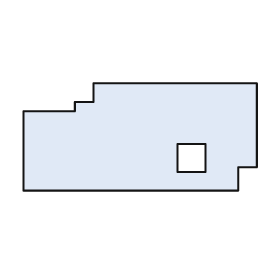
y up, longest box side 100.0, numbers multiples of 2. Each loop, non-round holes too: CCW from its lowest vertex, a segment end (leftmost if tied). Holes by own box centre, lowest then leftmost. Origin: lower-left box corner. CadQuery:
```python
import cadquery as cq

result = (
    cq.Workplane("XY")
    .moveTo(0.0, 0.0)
    .lineTo(92.0, 0.0)
    .lineTo(92.0, 10.0)
    .lineTo(100.0, 10.0)
    .lineTo(100.0, 46.0)
    .lineTo(30.0, 46.0)
    .lineTo(30.0, 38.0)
    .lineTo(22.0, 38.0)
    .lineTo(22.0, 34.0)
    .lineTo(0.0, 34.0)
    .close()
    .moveTo(66.0, 8.0)
    .lineTo(78.0, 8.0)
    .lineTo(78.0, 20.0)
    .lineTo(66.0, 20.0)
    .close()
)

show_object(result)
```